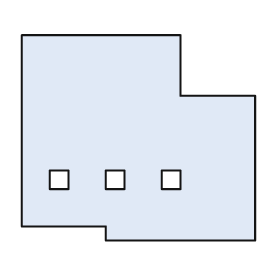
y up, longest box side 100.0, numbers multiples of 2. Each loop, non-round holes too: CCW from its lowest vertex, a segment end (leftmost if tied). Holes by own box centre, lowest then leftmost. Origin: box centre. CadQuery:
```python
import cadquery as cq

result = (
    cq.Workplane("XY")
    .moveTo(-14.0, -44.0)
    .lineTo(50.0, -44.0)
    .lineTo(50.0, 18.0)
    .lineTo(18.0, 18.0)
    .lineTo(18.0, 44.0)
    .lineTo(-50.0, 44.0)
    .lineTo(-50.0, -38.0)
    .lineTo(-14.0, -38.0)
    .close()
    .moveTo(-38.0, -22.0)
    .lineTo(-30.0, -22.0)
    .lineTo(-30.0, -14.0)
    .lineTo(-38.0, -14.0)
    .close()
    .moveTo(-14.0, -22.0)
    .lineTo(-6.0, -22.0)
    .lineTo(-6.0, -14.0)
    .lineTo(-14.0, -14.0)
    .close()
    .moveTo(10.0, -22.0)
    .lineTo(18.0, -22.0)
    .lineTo(18.0, -14.0)
    .lineTo(10.0, -14.0)
    .close()
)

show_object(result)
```